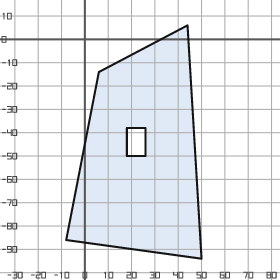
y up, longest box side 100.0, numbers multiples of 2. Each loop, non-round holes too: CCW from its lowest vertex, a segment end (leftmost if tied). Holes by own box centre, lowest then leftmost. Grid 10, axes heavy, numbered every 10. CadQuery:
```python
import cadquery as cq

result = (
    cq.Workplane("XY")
    .moveTo(50.0, -94.0)
    .lineTo(44.0, 6.0)
    .lineTo(6.0, -14.0)
    .lineTo(-8.0, -86.0)
    .close()
    .moveTo(18.0, -50.0)
    .lineTo(26.0, -50.0)
    .lineTo(26.0, -38.0)
    .lineTo(18.0, -38.0)
    .close()
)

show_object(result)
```